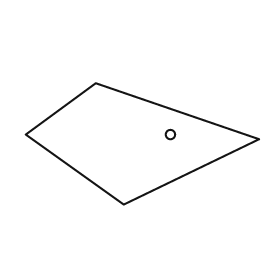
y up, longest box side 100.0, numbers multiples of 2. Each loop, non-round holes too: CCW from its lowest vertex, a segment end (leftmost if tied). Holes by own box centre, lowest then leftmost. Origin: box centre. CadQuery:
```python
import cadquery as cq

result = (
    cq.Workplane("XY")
    .moveTo(-8.0, -26.0)
    .lineTo(50.0, 2.0)
    .lineTo(-20.0, 26.0)
    .lineTo(-50.0, 4.0)
    .close()
    .moveTo(12.0, 4.0)
    .circle(2.0)
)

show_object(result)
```